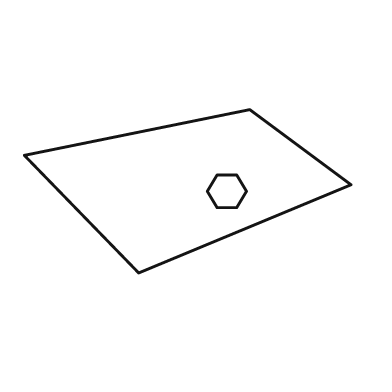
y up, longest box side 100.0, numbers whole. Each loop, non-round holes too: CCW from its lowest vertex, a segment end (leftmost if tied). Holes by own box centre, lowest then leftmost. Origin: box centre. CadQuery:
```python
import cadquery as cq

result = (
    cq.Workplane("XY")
    .moveTo(-15.0, -25.0)
    .lineTo(50.0, 2.0)
    .lineTo(19.0, 25.0)
    .lineTo(-50.0, 11.0)
    .close()
    .moveTo(9.0, -5.0)
    .lineTo(15.0, -5.0)
    .lineTo(18.0, 0.0)
    .lineTo(15.0, 5.0)
    .lineTo(9.0, 5.0)
    .lineTo(6.0, 0.0)
    .close()
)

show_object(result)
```